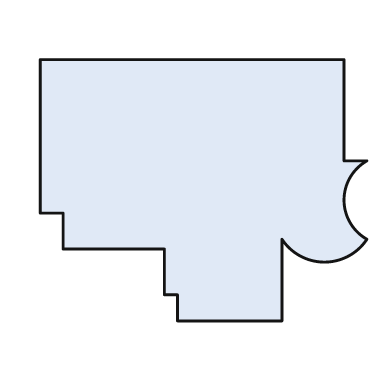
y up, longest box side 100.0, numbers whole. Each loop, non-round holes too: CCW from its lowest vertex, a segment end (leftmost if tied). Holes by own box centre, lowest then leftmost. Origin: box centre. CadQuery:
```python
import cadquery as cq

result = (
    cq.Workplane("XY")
    .moveTo(-8.0, -40.0)
    .lineTo(24.0, -40.0)
    .lineTo(24.0, -15.0)
    .threePointArc((37.0, -22.0), (50.0, -15.0))
    .threePointArc((43.0, -3.0), (50.0, 9.0))
    .lineTo(43.0, 9.0)
    .lineTo(43.0, 40.0)
    .lineTo(-50.0, 40.0)
    .lineTo(-50.0, -7.0)
    .lineTo(-43.0, -7.0)
    .lineTo(-43.0, -18.0)
    .lineTo(-12.0, -18.0)
    .lineTo(-12.0, -32.0)
    .lineTo(-8.0, -32.0)
    .close()
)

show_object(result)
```